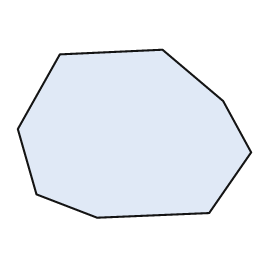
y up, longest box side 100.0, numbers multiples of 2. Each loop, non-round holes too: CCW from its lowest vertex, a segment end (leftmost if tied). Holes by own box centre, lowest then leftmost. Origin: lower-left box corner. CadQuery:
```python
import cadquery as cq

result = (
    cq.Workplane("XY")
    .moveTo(34.0, 0.0)
    .lineTo(82.0, 2.0)
    .lineTo(100.0, 28.0)
    .lineTo(88.0, 50.0)
    .lineTo(62.0, 72.0)
    .lineTo(18.0, 70.0)
    .lineTo(0.0, 38.0)
    .lineTo(8.0, 10.0)
    .close()
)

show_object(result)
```